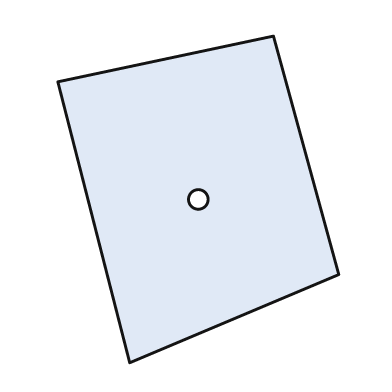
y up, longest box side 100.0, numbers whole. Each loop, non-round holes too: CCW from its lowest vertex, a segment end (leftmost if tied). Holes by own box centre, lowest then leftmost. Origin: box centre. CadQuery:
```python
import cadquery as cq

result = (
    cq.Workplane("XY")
    .moveTo(-21.0, -50.0)
    .lineTo(43.0, -23.0)
    .lineTo(23.0, 50.0)
    .lineTo(-43.0, 36.0)
    .close()
    .moveTo(0.0, 0.0)
    .circle(3.0)
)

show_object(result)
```